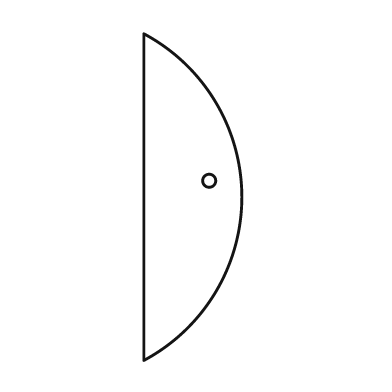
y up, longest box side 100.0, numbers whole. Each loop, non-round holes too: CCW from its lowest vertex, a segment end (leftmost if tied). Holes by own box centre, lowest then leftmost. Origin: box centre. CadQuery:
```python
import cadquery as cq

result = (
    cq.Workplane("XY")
    .moveTo(-15.0, -50.0)
    .threePointArc((15.0, 0.0), (-15.0, 50.0))
    .close()
    .moveTo(5.0, 5.0)
    .circle(2.0)
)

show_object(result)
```